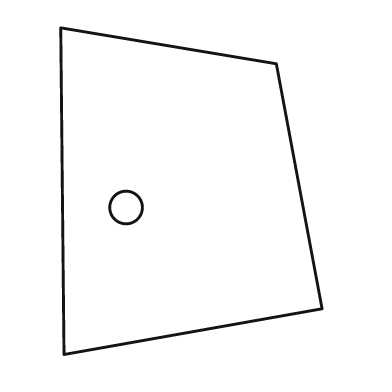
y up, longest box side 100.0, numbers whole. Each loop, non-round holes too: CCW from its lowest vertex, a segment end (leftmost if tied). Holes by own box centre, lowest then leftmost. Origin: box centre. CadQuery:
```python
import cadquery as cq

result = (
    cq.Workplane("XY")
    .moveTo(-39.0, -50.0)
    .lineTo(40.0, -36.0)
    .lineTo(26.0, 39.0)
    .lineTo(-40.0, 50.0)
    .close()
    .moveTo(-20.0, -5.0)
    .circle(5.0)
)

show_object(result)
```